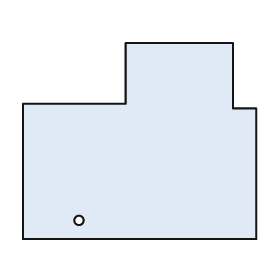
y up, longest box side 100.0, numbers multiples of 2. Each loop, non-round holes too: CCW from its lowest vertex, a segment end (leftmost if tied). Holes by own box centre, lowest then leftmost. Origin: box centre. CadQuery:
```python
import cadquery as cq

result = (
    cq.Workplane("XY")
    .moveTo(-50.0, -42.0)
    .lineTo(50.0, -42.0)
    .lineTo(50.0, 14.0)
    .lineTo(40.0, 14.0)
    .lineTo(40.0, 42.0)
    .lineTo(-6.0, 42.0)
    .lineTo(-6.0, 16.0)
    .lineTo(-50.0, 16.0)
    .close()
    .moveTo(-26.0, -34.0)
    .circle(2.0)
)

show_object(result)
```